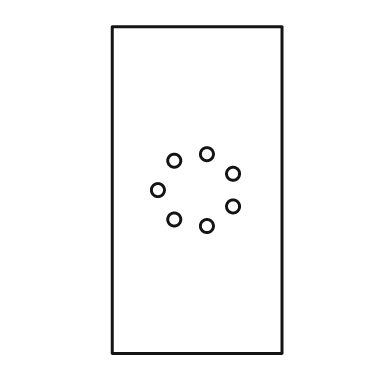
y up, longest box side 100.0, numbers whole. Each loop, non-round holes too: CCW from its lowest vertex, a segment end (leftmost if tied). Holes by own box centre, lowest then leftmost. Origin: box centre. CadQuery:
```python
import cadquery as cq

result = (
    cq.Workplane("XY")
    .moveTo(-26.0, -50.0)
    .lineTo(26.0, -50.0)
    .lineTo(26.0, 50.0)
    .lineTo(-26.0, 50.0)
    .close()
    .moveTo(3.0, -11.0)
    .circle(2.0)
    .moveTo(-7.0, -9.0)
    .circle(2.0)
    .moveTo(11.0, -5.0)
    .circle(2.0)
    .moveTo(-12.0, 0.0)
    .circle(2.0)
    .moveTo(11.0, 5.0)
    .circle(2.0)
    .moveTo(-7.0, 9.0)
    .circle(2.0)
    .moveTo(3.0, 11.0)
    .circle(2.0)
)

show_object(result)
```